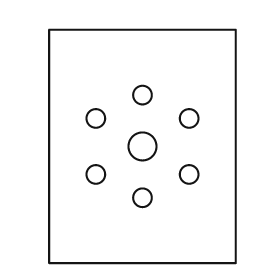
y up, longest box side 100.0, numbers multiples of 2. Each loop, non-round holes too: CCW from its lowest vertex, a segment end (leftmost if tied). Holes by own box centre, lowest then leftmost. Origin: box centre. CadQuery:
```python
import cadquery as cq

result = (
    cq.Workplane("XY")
    .moveTo(-40.0, -50.0)
    .lineTo(40.0, -50.0)
    .lineTo(40.0, 50.0)
    .lineTo(-40.0, 50.0)
    .close()
    .moveTo(0.0, -22.0)
    .circle(4.0)
    .moveTo(-20.0, -12.0)
    .circle(4.0)
    .moveTo(20.0, -12.0)
    .circle(4.0)
    .moveTo(0.0, 0.0)
    .circle(6.0)
    .moveTo(-20.0, 12.0)
    .circle(4.0)
    .moveTo(20.0, 12.0)
    .circle(4.0)
    .moveTo(0.0, 22.0)
    .circle(4.0)
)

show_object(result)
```